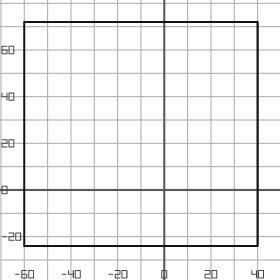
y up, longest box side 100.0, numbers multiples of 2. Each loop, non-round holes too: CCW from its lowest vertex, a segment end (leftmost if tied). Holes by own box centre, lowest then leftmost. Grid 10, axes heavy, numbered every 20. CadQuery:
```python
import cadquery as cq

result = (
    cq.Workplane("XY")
    .moveTo(-60.0, -24.0)
    .lineTo(40.0, -24.0)
    .lineTo(40.0, 72.0)
    .lineTo(-60.0, 72.0)
    .close()
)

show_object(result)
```